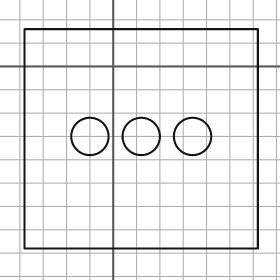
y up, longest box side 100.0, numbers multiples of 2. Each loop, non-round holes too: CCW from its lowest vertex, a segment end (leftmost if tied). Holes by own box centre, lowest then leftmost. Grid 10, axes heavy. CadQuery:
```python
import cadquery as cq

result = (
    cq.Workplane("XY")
    .moveTo(-38.0, -78.0)
    .lineTo(62.0, -78.0)
    .lineTo(62.0, 16.0)
    .lineTo(-38.0, 16.0)
    .close()
    .moveTo(-10.0, -30.0)
    .circle(8.0)
    .moveTo(12.0, -30.0)
    .circle(8.0)
    .moveTo(34.0, -30.0)
    .circle(8.0)
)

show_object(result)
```